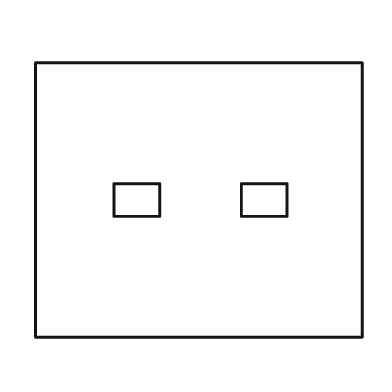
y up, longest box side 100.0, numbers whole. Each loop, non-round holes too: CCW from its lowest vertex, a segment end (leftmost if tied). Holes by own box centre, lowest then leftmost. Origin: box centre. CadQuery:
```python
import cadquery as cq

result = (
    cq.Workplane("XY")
    .moveTo(-50.0, -42.0)
    .lineTo(50.0, -42.0)
    .lineTo(50.0, 42.0)
    .lineTo(-50.0, 42.0)
    .close()
    .moveTo(-26.0, -5.0)
    .lineTo(-12.0, -5.0)
    .lineTo(-12.0, 5.0)
    .lineTo(-26.0, 5.0)
    .close()
    .moveTo(13.0, -5.0)
    .lineTo(27.0, -5.0)
    .lineTo(27.0, 5.0)
    .lineTo(13.0, 5.0)
    .close()
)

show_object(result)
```